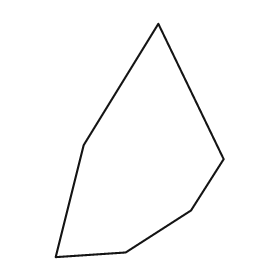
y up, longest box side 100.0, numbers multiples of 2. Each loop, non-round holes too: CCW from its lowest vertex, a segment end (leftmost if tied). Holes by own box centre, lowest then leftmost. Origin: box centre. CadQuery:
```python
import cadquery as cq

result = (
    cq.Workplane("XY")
    .moveTo(-36.0, -50.0)
    .lineTo(-6.0, -48.0)
    .lineTo(22.0, -30.0)
    .lineTo(36.0, -8.0)
    .lineTo(8.0, 50.0)
    .lineTo(-24.0, -2.0)
    .close()
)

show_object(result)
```